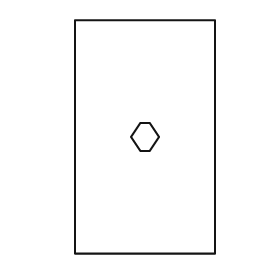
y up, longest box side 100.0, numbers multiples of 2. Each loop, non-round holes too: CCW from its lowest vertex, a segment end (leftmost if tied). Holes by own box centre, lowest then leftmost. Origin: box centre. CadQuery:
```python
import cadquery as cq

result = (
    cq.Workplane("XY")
    .moveTo(-30.0, -50.0)
    .lineTo(30.0, -50.0)
    .lineTo(30.0, 50.0)
    .lineTo(-30.0, 50.0)
    .close()
    .moveTo(-2.0, -6.0)
    .lineTo(2.0, -6.0)
    .lineTo(6.0, 0.0)
    .lineTo(2.0, 6.0)
    .lineTo(-2.0, 6.0)
    .lineTo(-6.0, 0.0)
    .close()
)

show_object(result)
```